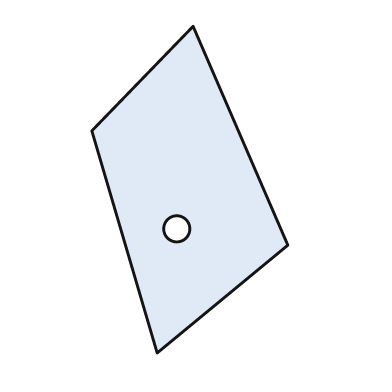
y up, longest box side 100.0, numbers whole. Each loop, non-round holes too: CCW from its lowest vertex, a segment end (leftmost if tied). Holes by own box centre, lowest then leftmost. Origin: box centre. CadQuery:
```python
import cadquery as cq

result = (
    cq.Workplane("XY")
    .moveTo(-10.0, -50.0)
    .lineTo(30.0, -17.0)
    .lineTo(1.0, 50.0)
    .lineTo(-30.0, 18.0)
    .close()
    .moveTo(-4.0, -12.0)
    .circle(4.0)
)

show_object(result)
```